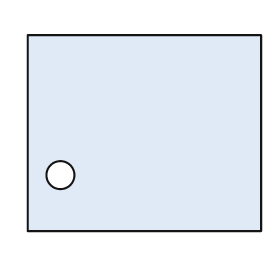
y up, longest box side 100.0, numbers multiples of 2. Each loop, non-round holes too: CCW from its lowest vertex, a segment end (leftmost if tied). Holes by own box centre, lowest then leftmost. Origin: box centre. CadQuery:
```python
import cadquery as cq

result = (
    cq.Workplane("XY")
    .moveTo(-50.0, -42.0)
    .lineTo(50.0, -42.0)
    .lineTo(50.0, 42.0)
    .lineTo(-50.0, 42.0)
    .close()
    .moveTo(-36.0, -18.0)
    .circle(6.0)
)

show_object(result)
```